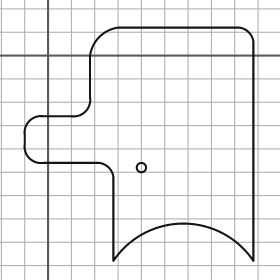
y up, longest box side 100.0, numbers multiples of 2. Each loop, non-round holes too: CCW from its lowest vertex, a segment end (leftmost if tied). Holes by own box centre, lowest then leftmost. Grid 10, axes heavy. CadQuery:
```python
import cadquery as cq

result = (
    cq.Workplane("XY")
    .moveTo(28.0, -88.0)
    .threePointArc((58.0, -72.0), (88.0, -88.0))
    .lineTo(88.0, 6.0)
    .threePointArc((86.0, 10.0), (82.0, 12.0))
    .lineTo(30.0, 12.0)
    .threePointArc((22.0, 8.0), (18.0, 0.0))
    .lineTo(18.0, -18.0)
    .threePointArc((16.0, -24.0), (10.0, -26.0))
    .lineTo(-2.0, -26.0)
    .threePointArc((-8.0, -28.0), (-10.0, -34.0))
    .lineTo(-10.0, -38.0)
    .threePointArc((-8.0, -44.0), (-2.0, -46.0))
    .lineTo(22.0, -46.0)
    .threePointArc((26.0, -48.0), (28.0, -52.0))
    .close()
    .moveTo(40.0, -48.0)
    .circle(2.0)
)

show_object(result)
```